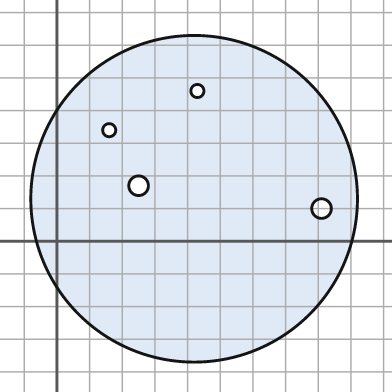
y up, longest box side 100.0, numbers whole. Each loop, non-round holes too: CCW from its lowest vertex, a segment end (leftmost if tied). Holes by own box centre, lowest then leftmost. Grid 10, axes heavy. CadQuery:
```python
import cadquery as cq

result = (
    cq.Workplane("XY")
    .moveTo(42.0, 13.0)
    .circle(50.0)
    .moveTo(81.0, 10.0)
    .circle(3.0)
    .moveTo(25.0, 17.0)
    .circle(3.0)
    .moveTo(16.0, 34.0)
    .circle(2.0)
    .moveTo(43.0, 46.0)
    .circle(2.0)
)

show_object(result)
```